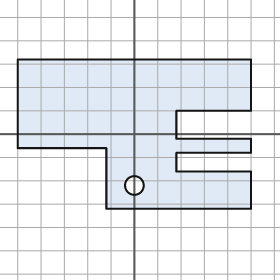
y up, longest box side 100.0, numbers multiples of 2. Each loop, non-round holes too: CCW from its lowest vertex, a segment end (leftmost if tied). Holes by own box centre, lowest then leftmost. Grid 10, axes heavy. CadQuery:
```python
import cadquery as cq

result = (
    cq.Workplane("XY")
    .moveTo(-12.0, -32.0)
    .lineTo(50.0, -32.0)
    .lineTo(50.0, -16.0)
    .lineTo(18.0, -16.0)
    .lineTo(18.0, -8.0)
    .lineTo(50.0, -8.0)
    .lineTo(50.0, -2.0)
    .lineTo(18.0, -2.0)
    .lineTo(18.0, 10.0)
    .lineTo(50.0, 10.0)
    .lineTo(50.0, 32.0)
    .lineTo(-50.0, 32.0)
    .lineTo(-50.0, -6.0)
    .lineTo(-12.0, -6.0)
    .close()
    .moveTo(0.0, -22.0)
    .circle(4.0)
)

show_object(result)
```